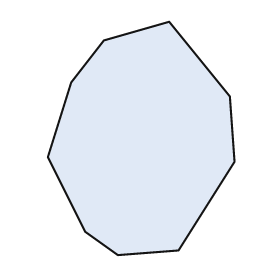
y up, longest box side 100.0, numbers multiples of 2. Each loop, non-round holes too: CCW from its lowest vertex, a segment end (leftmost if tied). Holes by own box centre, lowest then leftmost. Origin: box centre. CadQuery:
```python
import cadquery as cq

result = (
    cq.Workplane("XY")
    .moveTo(-10.0, -50.0)
    .lineTo(16.0, -48.0)
    .lineTo(40.0, -10.0)
    .lineTo(38.0, 18.0)
    .lineTo(12.0, 50.0)
    .lineTo(-16.0, 42.0)
    .lineTo(-30.0, 24.0)
    .lineTo(-40.0, -8.0)
    .lineTo(-24.0, -40.0)
    .close()
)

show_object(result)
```